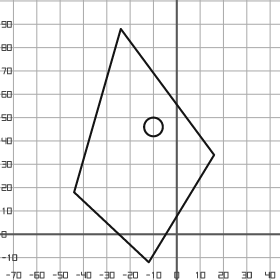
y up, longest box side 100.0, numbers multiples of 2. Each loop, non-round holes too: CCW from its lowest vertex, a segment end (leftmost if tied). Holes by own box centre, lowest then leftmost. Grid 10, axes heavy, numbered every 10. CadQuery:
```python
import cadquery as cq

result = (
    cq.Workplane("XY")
    .moveTo(-12.0, -12.0)
    .lineTo(16.0, 34.0)
    .lineTo(-24.0, 88.0)
    .lineTo(-44.0, 18.0)
    .close()
    .moveTo(-10.0, 46.0)
    .circle(4.0)
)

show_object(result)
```